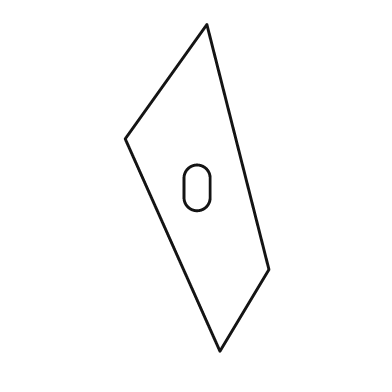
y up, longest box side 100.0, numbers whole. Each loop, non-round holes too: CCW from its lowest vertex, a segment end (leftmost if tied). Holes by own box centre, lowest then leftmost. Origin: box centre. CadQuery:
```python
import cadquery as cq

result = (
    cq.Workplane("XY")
    .moveTo(7.0, -50.0)
    .lineTo(22.0, -25.0)
    .lineTo(3.0, 50.0)
    .lineTo(-22.0, 15.0)
    .close()
    .moveTo(-4.0, -3.0)
    .threePointArc((0.0, -7.0), (4.0, -3.0))
    .lineTo(4.0, 3.0)
    .threePointArc((0.0, 7.0), (-4.0, 3.0))
    .close()
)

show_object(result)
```